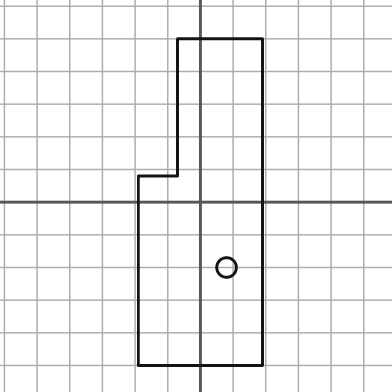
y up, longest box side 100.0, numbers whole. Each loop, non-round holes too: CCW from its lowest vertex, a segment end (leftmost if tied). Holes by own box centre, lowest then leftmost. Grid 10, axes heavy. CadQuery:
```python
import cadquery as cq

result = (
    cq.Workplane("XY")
    .moveTo(-19.0, -50.0)
    .lineTo(19.0, -50.0)
    .lineTo(19.0, 50.0)
    .lineTo(-7.0, 50.0)
    .lineTo(-7.0, 8.0)
    .lineTo(-19.0, 8.0)
    .close()
    .moveTo(8.0, -20.0)
    .circle(3.0)
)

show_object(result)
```